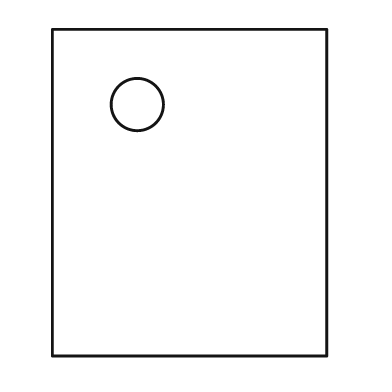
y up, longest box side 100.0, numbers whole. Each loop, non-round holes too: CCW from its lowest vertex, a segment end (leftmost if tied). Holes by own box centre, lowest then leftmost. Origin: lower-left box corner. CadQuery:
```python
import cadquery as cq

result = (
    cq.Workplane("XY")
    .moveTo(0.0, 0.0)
    .lineTo(84.0, 0.0)
    .lineTo(84.0, 100.0)
    .lineTo(0.0, 100.0)
    .close()
    .moveTo(26.0, 77.0)
    .circle(8.0)
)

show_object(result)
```